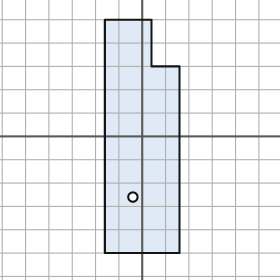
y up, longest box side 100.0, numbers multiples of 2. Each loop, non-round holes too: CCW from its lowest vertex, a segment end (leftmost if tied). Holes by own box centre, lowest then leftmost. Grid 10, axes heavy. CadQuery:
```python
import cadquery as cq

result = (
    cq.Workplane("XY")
    .moveTo(-16.0, -50.0)
    .lineTo(16.0, -50.0)
    .lineTo(16.0, 30.0)
    .lineTo(4.0, 30.0)
    .lineTo(4.0, 50.0)
    .lineTo(-16.0, 50.0)
    .close()
    .moveTo(-4.0, -26.0)
    .circle(2.0)
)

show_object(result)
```